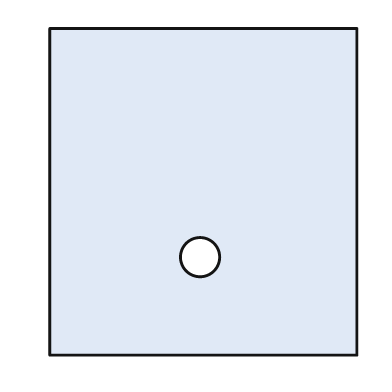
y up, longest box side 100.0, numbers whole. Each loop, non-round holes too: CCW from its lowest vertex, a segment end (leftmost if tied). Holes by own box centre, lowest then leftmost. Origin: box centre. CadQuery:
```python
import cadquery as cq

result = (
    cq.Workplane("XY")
    .moveTo(-47.0, -50.0)
    .lineTo(47.0, -50.0)
    .lineTo(47.0, 50.0)
    .lineTo(-47.0, 50.0)
    .close()
    .moveTo(-1.0, -20.0)
    .circle(6.0)
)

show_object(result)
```